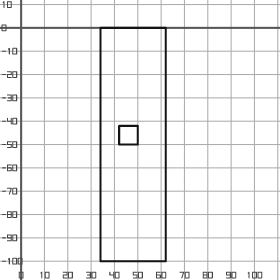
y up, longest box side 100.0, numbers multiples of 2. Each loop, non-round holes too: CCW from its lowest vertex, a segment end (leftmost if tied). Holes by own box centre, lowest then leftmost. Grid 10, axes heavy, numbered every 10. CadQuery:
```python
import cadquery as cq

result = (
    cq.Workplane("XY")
    .moveTo(34.0, -100.0)
    .lineTo(62.0, -100.0)
    .lineTo(62.0, 0.0)
    .lineTo(34.0, 0.0)
    .close()
    .moveTo(42.0, -50.0)
    .lineTo(50.0, -50.0)
    .lineTo(50.0, -42.0)
    .lineTo(42.0, -42.0)
    .close()
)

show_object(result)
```